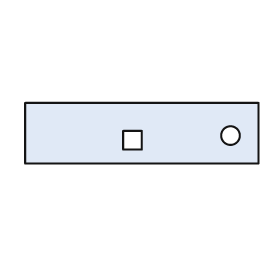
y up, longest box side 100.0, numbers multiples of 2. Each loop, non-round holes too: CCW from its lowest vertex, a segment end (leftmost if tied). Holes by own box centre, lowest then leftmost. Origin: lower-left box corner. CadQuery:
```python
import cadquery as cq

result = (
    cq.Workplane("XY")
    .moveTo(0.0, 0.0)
    .lineTo(100.0, 0.0)
    .lineTo(100.0, 26.0)
    .lineTo(0.0, 26.0)
    .close()
    .moveTo(42.0, 6.0)
    .lineTo(50.0, 6.0)
    .lineTo(50.0, 14.0)
    .lineTo(42.0, 14.0)
    .close()
    .moveTo(88.0, 12.0)
    .circle(4.0)
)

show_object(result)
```